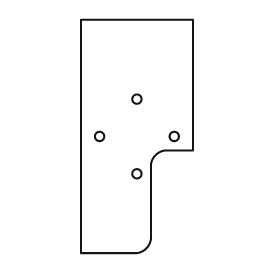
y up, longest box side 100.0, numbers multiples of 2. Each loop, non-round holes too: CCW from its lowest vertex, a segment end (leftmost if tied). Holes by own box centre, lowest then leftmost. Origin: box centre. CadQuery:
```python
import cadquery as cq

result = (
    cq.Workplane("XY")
    .moveTo(-24.0, -50.0)
    .lineTo(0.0, -50.0)
    .threePointArc((4.0, -48.0), (6.0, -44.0))
    .lineTo(6.0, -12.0)
    .threePointArc((8.0, -8.0), (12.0, -6.0))
    .lineTo(24.0, -6.0)
    .lineTo(24.0, 50.0)
    .lineTo(-24.0, 50.0)
    .close()
    .moveTo(0.0, -16.0)
    .circle(2.0)
    .moveTo(-16.0, 0.0)
    .circle(2.0)
    .moveTo(16.0, 0.0)
    .circle(2.0)
    .moveTo(0.0, 16.0)
    .circle(2.0)
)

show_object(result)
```